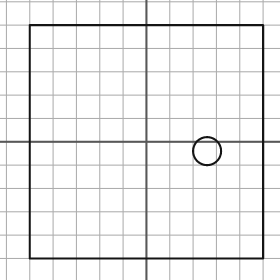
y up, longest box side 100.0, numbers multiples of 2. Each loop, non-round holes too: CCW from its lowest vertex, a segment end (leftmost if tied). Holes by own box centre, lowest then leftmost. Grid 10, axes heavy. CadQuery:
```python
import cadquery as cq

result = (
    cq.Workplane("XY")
    .moveTo(-50.0, -50.0)
    .lineTo(50.0, -50.0)
    .lineTo(50.0, 50.0)
    .lineTo(-50.0, 50.0)
    .close()
    .moveTo(26.0, -4.0)
    .circle(6.0)
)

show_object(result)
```